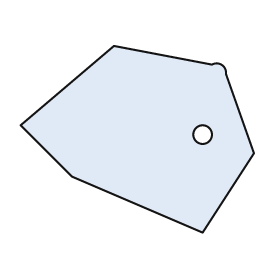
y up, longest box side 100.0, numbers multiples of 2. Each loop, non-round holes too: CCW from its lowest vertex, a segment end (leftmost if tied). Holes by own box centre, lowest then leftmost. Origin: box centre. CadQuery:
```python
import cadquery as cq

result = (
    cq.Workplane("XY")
    .moveTo(28.0, -40.0)
    .lineTo(50.0, -6.0)
    .lineTo(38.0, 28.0)
    .threePointArc((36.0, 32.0), (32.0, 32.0))
    .lineTo(-10.0, 40.0)
    .lineTo(-50.0, 6.0)
    .lineTo(-28.0, -16.0)
    .close()
    .moveTo(28.0, 2.0)
    .circle(4.0)
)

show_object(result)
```